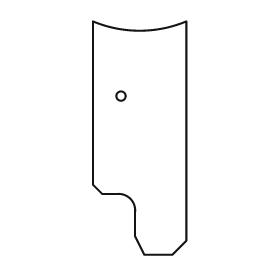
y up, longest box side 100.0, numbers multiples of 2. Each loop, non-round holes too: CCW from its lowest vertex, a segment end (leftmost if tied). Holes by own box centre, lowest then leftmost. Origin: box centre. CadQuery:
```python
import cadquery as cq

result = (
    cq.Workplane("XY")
    .moveTo(2.0, -50.0)
    .lineTo(14.0, -50.0)
    .lineTo(20.0, -44.0)
    .lineTo(20.0, 50.0)
    .threePointArc((0.0, 46.0), (-20.0, 50.0))
    .lineTo(-20.0, -20.0)
    .lineTo(-16.0, -24.0)
    .lineTo(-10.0, -24.0)
    .threePointArc((-4.0, -26.0), (-2.0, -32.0))
    .lineTo(-2.0, -42.0)
    .close()
    .moveTo(-8.0, 18.0)
    .circle(2.0)
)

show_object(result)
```